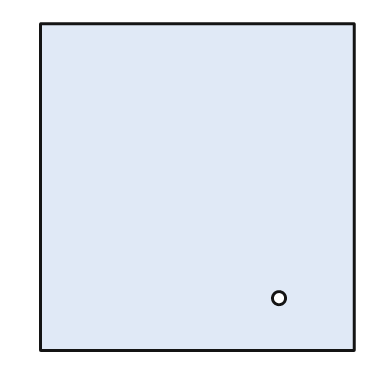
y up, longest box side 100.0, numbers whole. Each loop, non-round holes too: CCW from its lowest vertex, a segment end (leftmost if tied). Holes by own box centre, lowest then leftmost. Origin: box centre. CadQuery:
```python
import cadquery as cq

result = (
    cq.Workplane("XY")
    .moveTo(-48.0, -50.0)
    .lineTo(48.0, -50.0)
    .lineTo(48.0, 50.0)
    .lineTo(-48.0, 50.0)
    .close()
    .moveTo(25.0, -34.0)
    .circle(2.0)
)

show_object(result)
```